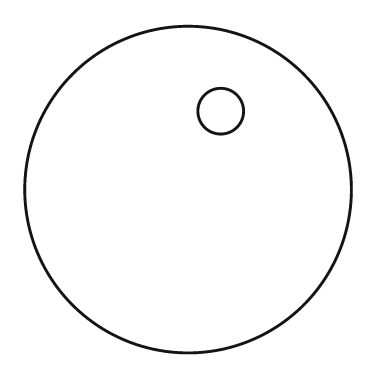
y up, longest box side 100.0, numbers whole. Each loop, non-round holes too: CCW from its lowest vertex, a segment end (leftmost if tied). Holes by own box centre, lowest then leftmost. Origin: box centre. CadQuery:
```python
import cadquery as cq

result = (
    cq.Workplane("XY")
    .moveTo(0.0, 0.0)
    .circle(50.0)
    .moveTo(10.0, 24.0)
    .circle(7.0)
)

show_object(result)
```